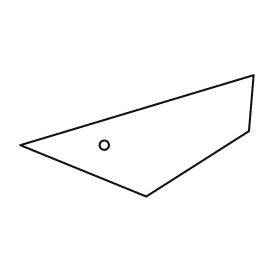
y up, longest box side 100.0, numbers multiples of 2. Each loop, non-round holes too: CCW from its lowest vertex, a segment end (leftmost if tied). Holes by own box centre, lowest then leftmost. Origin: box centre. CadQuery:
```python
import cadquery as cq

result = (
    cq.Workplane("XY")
    .moveTo(4.0, -26.0)
    .lineTo(48.0, 2.0)
    .lineTo(50.0, 26.0)
    .lineTo(-50.0, -4.0)
    .close()
    .moveTo(-14.0, -4.0)
    .circle(2.0)
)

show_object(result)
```